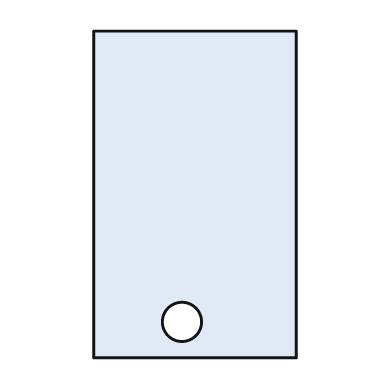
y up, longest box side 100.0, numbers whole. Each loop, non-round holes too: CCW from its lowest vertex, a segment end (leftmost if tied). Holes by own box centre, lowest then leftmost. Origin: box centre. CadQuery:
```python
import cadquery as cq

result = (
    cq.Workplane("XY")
    .moveTo(-31.0, -50.0)
    .lineTo(31.0, -50.0)
    .lineTo(31.0, 50.0)
    .lineTo(-31.0, 50.0)
    .close()
    .moveTo(-4.0, -39.0)
    .circle(6.0)
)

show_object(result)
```